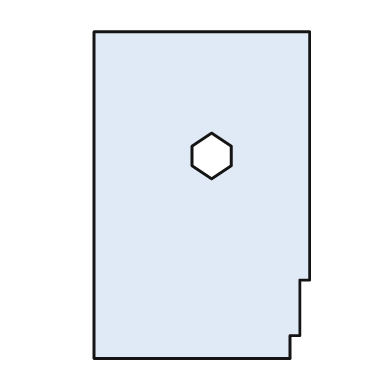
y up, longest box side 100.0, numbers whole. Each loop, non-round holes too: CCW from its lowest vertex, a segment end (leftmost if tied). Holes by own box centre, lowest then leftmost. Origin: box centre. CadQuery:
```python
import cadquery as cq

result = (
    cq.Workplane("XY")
    .moveTo(-33.0, -50.0)
    .lineTo(27.0, -50.0)
    .lineTo(27.0, -43.0)
    .lineTo(30.0, -43.0)
    .lineTo(30.0, -26.0)
    .lineTo(33.0, -26.0)
    .lineTo(33.0, 50.0)
    .lineTo(-33.0, 50.0)
    .close()
    .moveTo(3.0, 5.0)
    .lineTo(9.0, 9.0)
    .lineTo(9.0, 15.0)
    .lineTo(3.0, 19.0)
    .lineTo(-3.0, 15.0)
    .lineTo(-3.0, 9.0)
    .close()
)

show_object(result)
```